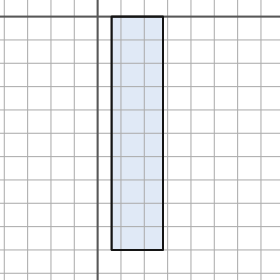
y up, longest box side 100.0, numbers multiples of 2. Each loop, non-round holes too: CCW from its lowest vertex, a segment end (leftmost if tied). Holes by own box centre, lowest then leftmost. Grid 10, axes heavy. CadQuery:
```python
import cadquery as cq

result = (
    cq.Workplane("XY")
    .moveTo(6.0, -100.0)
    .lineTo(28.0, -100.0)
    .lineTo(28.0, 0.0)
    .lineTo(6.0, 0.0)
    .close()
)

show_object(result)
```